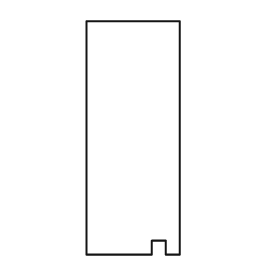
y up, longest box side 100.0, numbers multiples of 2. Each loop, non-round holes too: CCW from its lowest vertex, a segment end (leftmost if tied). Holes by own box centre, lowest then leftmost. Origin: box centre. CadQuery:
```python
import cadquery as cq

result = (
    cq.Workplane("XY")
    .moveTo(-20.0, -50.0)
    .lineTo(8.0, -50.0)
    .lineTo(8.0, -44.0)
    .lineTo(14.0, -44.0)
    .lineTo(14.0, -50.0)
    .lineTo(20.0, -50.0)
    .lineTo(20.0, 50.0)
    .lineTo(-20.0, 50.0)
    .close()
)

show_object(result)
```